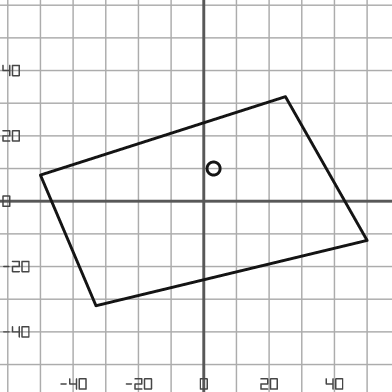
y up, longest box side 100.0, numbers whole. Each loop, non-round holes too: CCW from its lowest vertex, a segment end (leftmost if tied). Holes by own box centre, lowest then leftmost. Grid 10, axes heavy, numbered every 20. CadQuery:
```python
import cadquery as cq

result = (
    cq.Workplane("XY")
    .moveTo(-33.0, -32.0)
    .lineTo(50.0, -12.0)
    .lineTo(25.0, 32.0)
    .lineTo(-50.0, 8.0)
    .close()
    .moveTo(3.0, 10.0)
    .circle(2.0)
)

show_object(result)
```